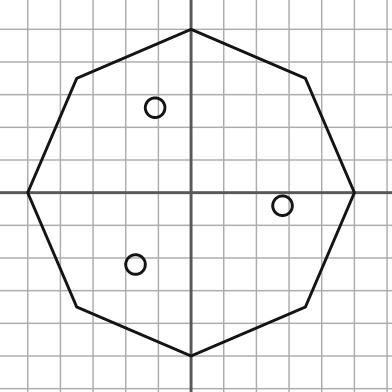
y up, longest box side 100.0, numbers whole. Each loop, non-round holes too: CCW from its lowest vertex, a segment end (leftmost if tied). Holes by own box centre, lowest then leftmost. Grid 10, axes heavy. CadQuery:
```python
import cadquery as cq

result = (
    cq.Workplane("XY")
    .moveTo(0.0, -50.0)
    .lineTo(35.0, -35.0)
    .lineTo(50.0, 0.0)
    .lineTo(35.0, 35.0)
    .lineTo(0.0, 50.0)
    .lineTo(-35.0, 35.0)
    .lineTo(-50.0, 0.0)
    .lineTo(-35.0, -35.0)
    .close()
    .moveTo(-17.0, -22.0)
    .circle(3.0)
    .moveTo(28.0, -4.0)
    .circle(3.0)
    .moveTo(-11.0, 26.0)
    .circle(3.0)
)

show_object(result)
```